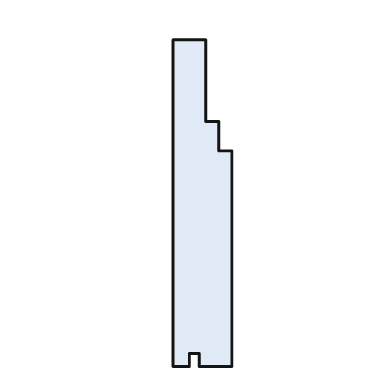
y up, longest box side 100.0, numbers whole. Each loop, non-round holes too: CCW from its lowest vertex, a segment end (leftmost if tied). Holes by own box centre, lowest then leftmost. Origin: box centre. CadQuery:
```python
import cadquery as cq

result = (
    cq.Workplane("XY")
    .moveTo(-9.0, -50.0)
    .lineTo(-4.0, -50.0)
    .lineTo(-4.0, -46.0)
    .lineTo(-1.0, -46.0)
    .lineTo(-1.0, -50.0)
    .lineTo(9.0, -50.0)
    .lineTo(9.0, 16.0)
    .lineTo(5.0, 16.0)
    .lineTo(5.0, 25.0)
    .lineTo(1.0, 25.0)
    .lineTo(1.0, 50.0)
    .lineTo(-9.0, 50.0)
    .close()
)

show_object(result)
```